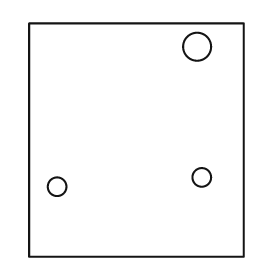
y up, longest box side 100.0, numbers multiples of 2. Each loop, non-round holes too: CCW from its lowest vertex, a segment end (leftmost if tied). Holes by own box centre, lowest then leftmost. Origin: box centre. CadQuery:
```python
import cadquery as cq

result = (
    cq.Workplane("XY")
    .moveTo(-46.0, -50.0)
    .lineTo(46.0, -50.0)
    .lineTo(46.0, 50.0)
    .lineTo(-46.0, 50.0)
    .close()
    .moveTo(-34.0, -20.0)
    .circle(4.0)
    .moveTo(28.0, -16.0)
    .circle(4.0)
    .moveTo(26.0, 40.0)
    .circle(6.0)
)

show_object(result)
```